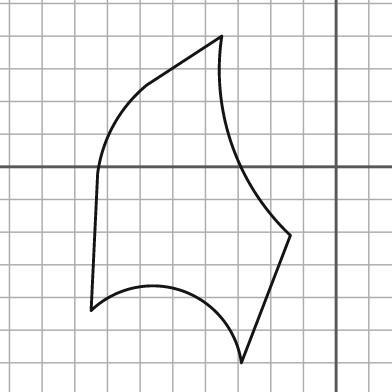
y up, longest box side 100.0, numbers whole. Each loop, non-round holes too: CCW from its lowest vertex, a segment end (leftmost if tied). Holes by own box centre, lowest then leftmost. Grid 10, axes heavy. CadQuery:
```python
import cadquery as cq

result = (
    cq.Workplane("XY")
    .moveTo(-29.0, -60.0)
    .lineTo(-14.0, -21.0)
    .threePointArc((-32.0, 7.0), (-35.0, 40.0))
    .lineTo(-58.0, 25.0)
    .threePointArc((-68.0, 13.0), (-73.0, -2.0))
    .lineTo(-75.0, -44.0)
    .threePointArc((-47.0, -38.0), (-29.0, -60.0))
    .close()
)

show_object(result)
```